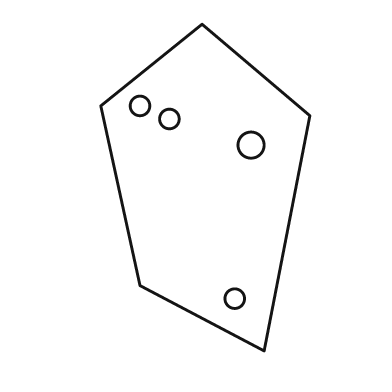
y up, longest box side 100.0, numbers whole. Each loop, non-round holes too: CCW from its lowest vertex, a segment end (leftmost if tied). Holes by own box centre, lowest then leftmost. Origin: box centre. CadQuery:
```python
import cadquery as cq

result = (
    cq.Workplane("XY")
    .moveTo(18.0, -50.0)
    .lineTo(32.0, 22.0)
    .lineTo(-1.0, 50.0)
    .lineTo(-32.0, 25.0)
    .lineTo(-20.0, -30.0)
    .close()
    .moveTo(9.0, -34.0)
    .circle(3.0)
    .moveTo(14.0, 13.0)
    .circle(4.0)
    .moveTo(-11.0, 21.0)
    .circle(3.0)
    .moveTo(-20.0, 25.0)
    .circle(3.0)
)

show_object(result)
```